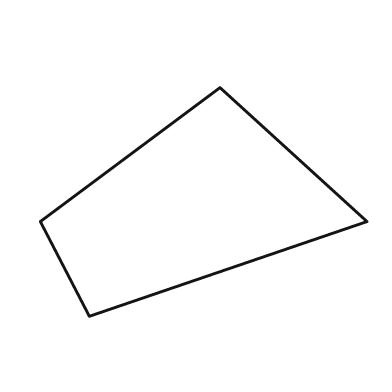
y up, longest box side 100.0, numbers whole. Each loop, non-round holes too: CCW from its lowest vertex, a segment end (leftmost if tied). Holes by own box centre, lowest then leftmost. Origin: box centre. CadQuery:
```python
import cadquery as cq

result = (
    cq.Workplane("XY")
    .moveTo(-35.0, -35.0)
    .lineTo(50.0, -6.0)
    .lineTo(5.0, 35.0)
    .lineTo(-50.0, -6.0)
    .close()
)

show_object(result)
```